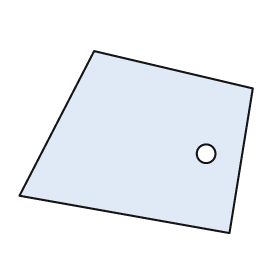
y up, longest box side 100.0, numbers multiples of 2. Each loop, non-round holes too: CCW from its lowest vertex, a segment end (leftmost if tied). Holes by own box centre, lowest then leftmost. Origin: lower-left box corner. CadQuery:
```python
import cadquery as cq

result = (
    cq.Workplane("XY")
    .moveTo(90.0, 0.0)
    .lineTo(100.0, 62.0)
    .lineTo(32.0, 78.0)
    .lineTo(0.0, 16.0)
    .close()
    .moveTo(80.0, 34.0)
    .circle(4.0)
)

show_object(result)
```